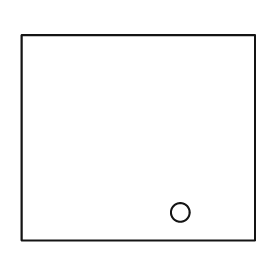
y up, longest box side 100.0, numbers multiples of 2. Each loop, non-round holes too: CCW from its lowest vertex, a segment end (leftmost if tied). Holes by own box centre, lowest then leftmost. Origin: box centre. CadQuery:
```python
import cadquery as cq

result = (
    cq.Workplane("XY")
    .moveTo(-50.0, -44.0)
    .lineTo(50.0, -44.0)
    .lineTo(50.0, 44.0)
    .lineTo(-50.0, 44.0)
    .close()
    .moveTo(18.0, -32.0)
    .circle(4.0)
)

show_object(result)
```